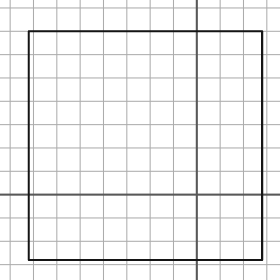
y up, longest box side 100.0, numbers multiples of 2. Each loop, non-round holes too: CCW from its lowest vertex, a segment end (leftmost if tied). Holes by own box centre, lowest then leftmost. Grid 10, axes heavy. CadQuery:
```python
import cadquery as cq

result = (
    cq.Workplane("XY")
    .moveTo(-72.0, -28.0)
    .lineTo(28.0, -28.0)
    .lineTo(28.0, 70.0)
    .lineTo(-72.0, 70.0)
    .close()
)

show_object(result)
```